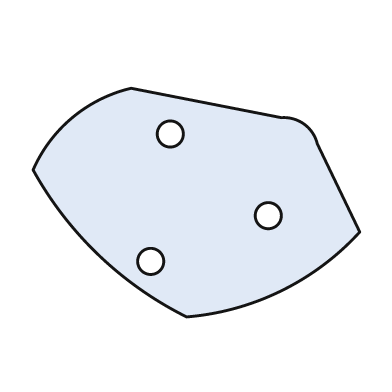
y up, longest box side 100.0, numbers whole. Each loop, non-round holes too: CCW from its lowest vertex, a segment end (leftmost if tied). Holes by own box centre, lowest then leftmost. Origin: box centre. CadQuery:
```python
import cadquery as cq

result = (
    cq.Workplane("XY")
    .moveTo(-3.0, -35.0)
    .threePointArc((26.0, -27.0), (50.0, -9.0))
    .lineTo(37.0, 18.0)
    .threePointArc((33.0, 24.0), (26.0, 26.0))
    .lineTo(-20.0, 35.0)
    .threePointArc((-38.0, 26.0), (-50.0, 10.0))
    .threePointArc((-30.0, -16.0), (-3.0, -35.0))
    .close()
    .moveTo(-14.0, -18.0)
    .circle(4.0)
    .moveTo(22.0, -4.0)
    .circle(4.0)
    .moveTo(-8.0, 21.0)
    .circle(4.0)
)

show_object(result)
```